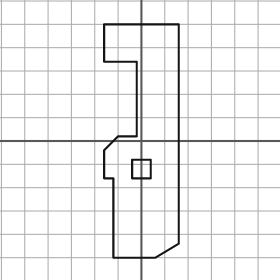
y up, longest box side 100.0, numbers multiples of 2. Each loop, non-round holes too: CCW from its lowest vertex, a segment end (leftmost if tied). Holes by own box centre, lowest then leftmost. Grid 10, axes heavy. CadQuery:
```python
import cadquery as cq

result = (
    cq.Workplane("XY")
    .moveTo(-12.0, -50.0)
    .lineTo(6.0, -50.0)
    .lineTo(16.0, -44.0)
    .lineTo(16.0, 50.0)
    .lineTo(-16.0, 50.0)
    .lineTo(-16.0, 34.0)
    .lineTo(-2.0, 34.0)
    .lineTo(-2.0, 2.0)
    .lineTo(-10.0, 2.0)
    .lineTo(-16.0, -4.0)
    .lineTo(-16.0, -16.0)
    .lineTo(-12.0, -16.0)
    .close()
    .moveTo(-4.0, -16.0)
    .lineTo(4.0, -16.0)
    .lineTo(4.0, -8.0)
    .lineTo(-4.0, -8.0)
    .close()
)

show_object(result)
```